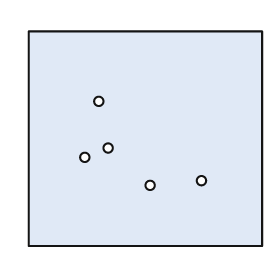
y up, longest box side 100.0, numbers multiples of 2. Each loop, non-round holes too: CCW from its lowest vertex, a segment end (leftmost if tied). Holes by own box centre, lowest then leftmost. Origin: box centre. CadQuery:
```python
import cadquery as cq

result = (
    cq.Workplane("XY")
    .moveTo(-50.0, -46.0)
    .lineTo(50.0, -46.0)
    .lineTo(50.0, 46.0)
    .lineTo(-50.0, 46.0)
    .close()
    .moveTo(2.0, -20.0)
    .circle(2.0)
    .moveTo(24.0, -18.0)
    .circle(2.0)
    .moveTo(-26.0, -8.0)
    .circle(2.0)
    .moveTo(-16.0, -4.0)
    .circle(2.0)
    .moveTo(-20.0, 16.0)
    .circle(2.0)
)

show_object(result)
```